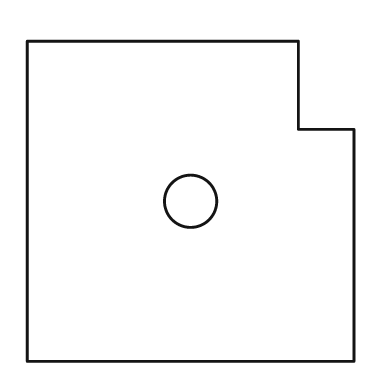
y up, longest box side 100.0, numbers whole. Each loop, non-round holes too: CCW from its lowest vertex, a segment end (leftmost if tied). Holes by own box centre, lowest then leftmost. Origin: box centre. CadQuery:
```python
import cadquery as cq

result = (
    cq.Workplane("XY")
    .moveTo(-50.0, -49.0)
    .lineTo(50.0, -49.0)
    .lineTo(50.0, 22.0)
    .lineTo(33.0, 22.0)
    .lineTo(33.0, 49.0)
    .lineTo(-50.0, 49.0)
    .close()
    .moveTo(0.0, 0.0)
    .circle(8.0)
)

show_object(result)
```